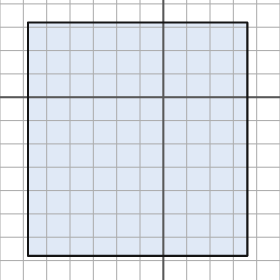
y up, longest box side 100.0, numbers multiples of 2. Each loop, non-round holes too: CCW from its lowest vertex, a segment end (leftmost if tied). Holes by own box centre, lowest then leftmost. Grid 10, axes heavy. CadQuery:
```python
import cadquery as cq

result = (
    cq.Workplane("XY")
    .moveTo(-58.0, -68.0)
    .lineTo(36.0, -68.0)
    .lineTo(36.0, 32.0)
    .lineTo(-58.0, 32.0)
    .close()
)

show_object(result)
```